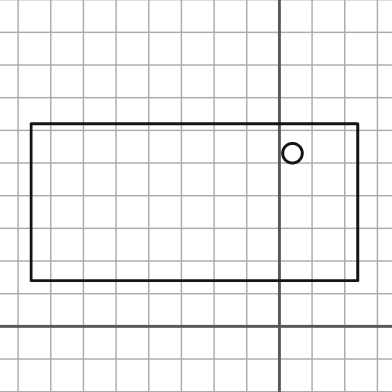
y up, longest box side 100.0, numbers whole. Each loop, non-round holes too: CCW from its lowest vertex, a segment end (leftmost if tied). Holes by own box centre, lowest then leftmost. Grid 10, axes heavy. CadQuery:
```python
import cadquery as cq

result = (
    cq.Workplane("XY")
    .moveTo(-76.0, 14.0)
    .lineTo(24.0, 14.0)
    .lineTo(24.0, 62.0)
    .lineTo(-76.0, 62.0)
    .close()
    .moveTo(4.0, 53.0)
    .circle(3.0)
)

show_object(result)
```